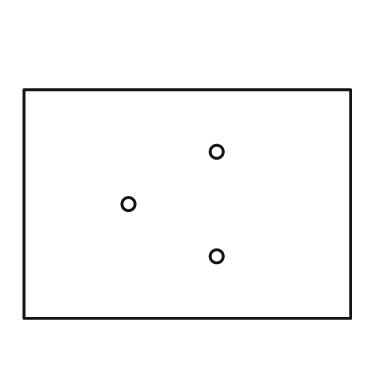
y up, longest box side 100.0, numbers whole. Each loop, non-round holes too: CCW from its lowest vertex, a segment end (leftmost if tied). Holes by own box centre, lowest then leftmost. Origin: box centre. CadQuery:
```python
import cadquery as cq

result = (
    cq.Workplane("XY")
    .moveTo(-50.0, -35.0)
    .lineTo(50.0, -35.0)
    .lineTo(50.0, 35.0)
    .lineTo(-50.0, 35.0)
    .close()
    .moveTo(9.0, -16.0)
    .circle(2.0)
    .moveTo(-18.0, 0.0)
    .circle(2.0)
    .moveTo(9.0, 16.0)
    .circle(2.0)
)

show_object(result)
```